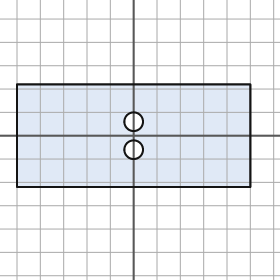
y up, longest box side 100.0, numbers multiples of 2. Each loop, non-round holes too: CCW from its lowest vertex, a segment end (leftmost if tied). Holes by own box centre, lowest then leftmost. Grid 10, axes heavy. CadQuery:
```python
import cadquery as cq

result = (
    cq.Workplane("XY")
    .moveTo(-50.0, -22.0)
    .lineTo(50.0, -22.0)
    .lineTo(50.0, 22.0)
    .lineTo(-50.0, 22.0)
    .close()
    .moveTo(0.0, -6.0)
    .circle(4.0)
    .moveTo(0.0, 6.0)
    .circle(4.0)
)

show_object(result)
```